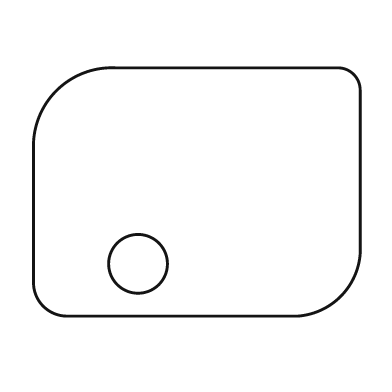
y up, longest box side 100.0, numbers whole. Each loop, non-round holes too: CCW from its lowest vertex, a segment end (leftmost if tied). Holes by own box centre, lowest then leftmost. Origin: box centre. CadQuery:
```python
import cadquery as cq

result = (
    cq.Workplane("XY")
    .moveTo(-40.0, -38.0)
    .lineTo(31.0, -38.0)
    .threePointArc((44.0, -32.0), (50.0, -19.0))
    .lineTo(50.0, 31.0)
    .threePointArc((48.0, 36.0), (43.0, 38.0))
    .lineTo(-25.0, 38.0)
    .threePointArc((-43.0, 31.0), (-50.0, 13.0))
    .lineTo(-50.0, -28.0)
    .threePointArc((-47.0, -35.0), (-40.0, -38.0))
    .close()
    .moveTo(-18.0, -22.0)
    .circle(9.0)
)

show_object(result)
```